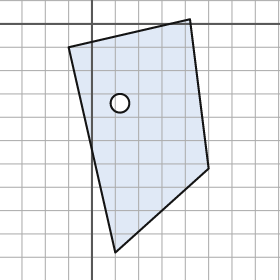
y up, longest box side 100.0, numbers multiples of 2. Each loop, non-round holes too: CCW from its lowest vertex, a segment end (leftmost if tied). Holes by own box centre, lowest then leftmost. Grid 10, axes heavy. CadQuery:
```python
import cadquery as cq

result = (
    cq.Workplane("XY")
    .moveTo(10.0, -98.0)
    .lineTo(50.0, -62.0)
    .lineTo(42.0, 2.0)
    .lineTo(-10.0, -10.0)
    .close()
    .moveTo(12.0, -34.0)
    .circle(4.0)
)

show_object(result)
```